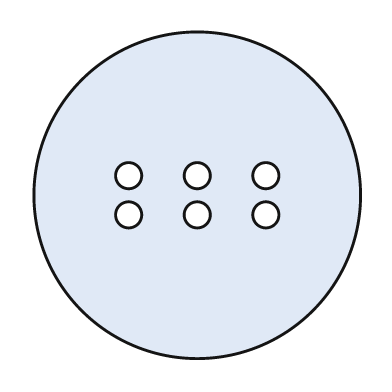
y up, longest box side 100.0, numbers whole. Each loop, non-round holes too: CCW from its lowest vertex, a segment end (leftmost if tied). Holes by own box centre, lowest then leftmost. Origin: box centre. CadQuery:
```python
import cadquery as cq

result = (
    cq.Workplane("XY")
    .moveTo(0.0, 0.0)
    .circle(50.0)
    .moveTo(-21.0, -6.0)
    .circle(4.0)
    .moveTo(0.0, -6.0)
    .circle(4.0)
    .moveTo(21.0, -6.0)
    .circle(4.0)
    .moveTo(-21.0, 6.0)
    .circle(4.0)
    .moveTo(0.0, 6.0)
    .circle(4.0)
    .moveTo(21.0, 6.0)
    .circle(4.0)
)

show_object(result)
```